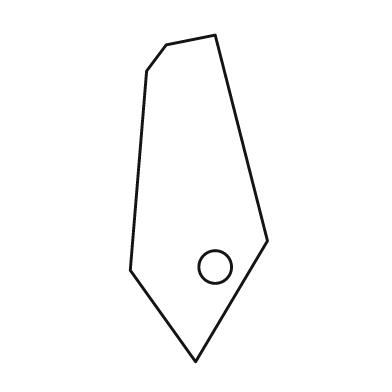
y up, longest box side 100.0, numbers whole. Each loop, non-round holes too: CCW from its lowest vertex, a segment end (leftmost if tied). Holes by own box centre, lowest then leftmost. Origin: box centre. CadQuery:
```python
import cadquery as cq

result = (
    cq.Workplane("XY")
    .moveTo(-1.0, -50.0)
    .lineTo(21.0, -13.0)
    .lineTo(5.0, 50.0)
    .lineTo(-10.0, 47.0)
    .lineTo(-16.0, 39.0)
    .lineTo(-21.0, -22.0)
    .close()
    .moveTo(5.0, -21.0)
    .circle(5.0)
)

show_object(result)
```